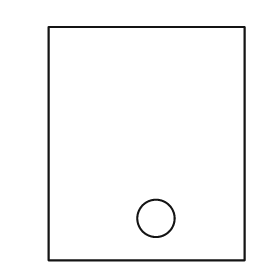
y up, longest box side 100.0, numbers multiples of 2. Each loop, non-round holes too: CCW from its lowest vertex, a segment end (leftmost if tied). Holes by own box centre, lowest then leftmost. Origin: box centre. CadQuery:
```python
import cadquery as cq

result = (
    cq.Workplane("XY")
    .moveTo(-42.0, -50.0)
    .lineTo(42.0, -50.0)
    .lineTo(42.0, 50.0)
    .lineTo(-42.0, 50.0)
    .close()
    .moveTo(4.0, -32.0)
    .circle(8.0)
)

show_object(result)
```